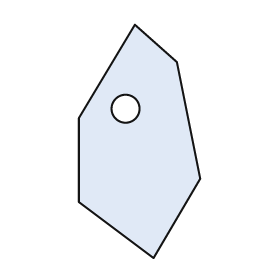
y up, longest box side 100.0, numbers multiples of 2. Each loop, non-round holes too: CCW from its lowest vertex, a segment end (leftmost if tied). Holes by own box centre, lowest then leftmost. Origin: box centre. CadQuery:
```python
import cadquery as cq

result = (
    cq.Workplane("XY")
    .moveTo(6.0, -50.0)
    .lineTo(26.0, -16.0)
    .lineTo(16.0, 34.0)
    .lineTo(-2.0, 50.0)
    .lineTo(-26.0, 10.0)
    .lineTo(-26.0, -26.0)
    .close()
    .moveTo(-6.0, 14.0)
    .circle(6.0)
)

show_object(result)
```